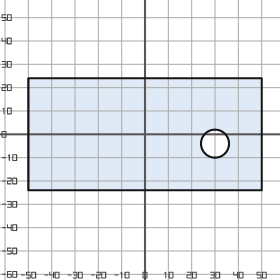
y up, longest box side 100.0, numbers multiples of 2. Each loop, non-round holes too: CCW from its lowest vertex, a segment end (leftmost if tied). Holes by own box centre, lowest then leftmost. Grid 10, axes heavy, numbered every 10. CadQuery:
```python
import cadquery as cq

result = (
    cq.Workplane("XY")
    .moveTo(-50.0, -24.0)
    .lineTo(50.0, -24.0)
    .lineTo(50.0, 24.0)
    .lineTo(-50.0, 24.0)
    .close()
    .moveTo(30.0, -4.0)
    .circle(6.0)
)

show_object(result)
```